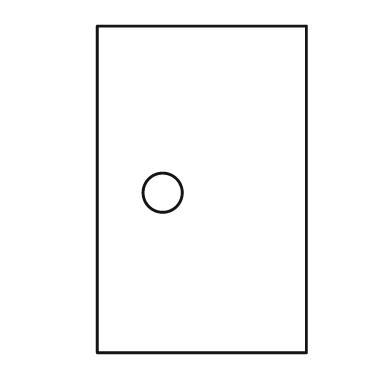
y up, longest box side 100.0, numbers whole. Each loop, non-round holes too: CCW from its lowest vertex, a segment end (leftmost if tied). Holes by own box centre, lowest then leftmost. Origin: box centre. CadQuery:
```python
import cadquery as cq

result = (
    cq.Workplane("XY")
    .moveTo(-32.0, -50.0)
    .lineTo(32.0, -50.0)
    .lineTo(32.0, 50.0)
    .lineTo(-32.0, 50.0)
    .close()
    .moveTo(-12.0, -1.0)
    .circle(6.0)
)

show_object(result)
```